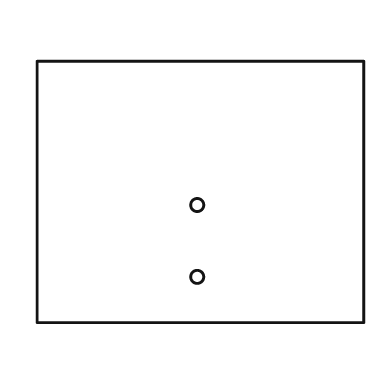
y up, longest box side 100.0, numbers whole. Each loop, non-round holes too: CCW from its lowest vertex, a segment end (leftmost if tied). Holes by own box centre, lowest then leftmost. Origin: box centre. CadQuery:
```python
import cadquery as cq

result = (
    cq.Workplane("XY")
    .moveTo(-50.0, -40.0)
    .lineTo(50.0, -40.0)
    .lineTo(50.0, 40.0)
    .lineTo(-50.0, 40.0)
    .close()
    .moveTo(-1.0, -26.0)
    .circle(2.0)
    .moveTo(-1.0, -4.0)
    .circle(2.0)
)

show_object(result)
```